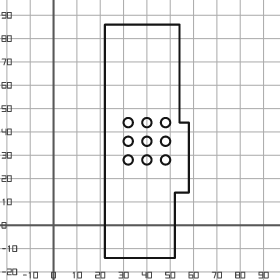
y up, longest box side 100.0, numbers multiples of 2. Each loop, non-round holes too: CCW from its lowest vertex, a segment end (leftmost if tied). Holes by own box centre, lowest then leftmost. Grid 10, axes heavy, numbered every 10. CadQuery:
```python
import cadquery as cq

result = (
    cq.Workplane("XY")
    .moveTo(22.0, -14.0)
    .lineTo(52.0, -14.0)
    .lineTo(52.0, 14.0)
    .lineTo(58.0, 14.0)
    .lineTo(58.0, 44.0)
    .lineTo(54.0, 44.0)
    .lineTo(54.0, 86.0)
    .lineTo(22.0, 86.0)
    .close()
    .moveTo(32.0, 28.0)
    .circle(2.0)
    .moveTo(40.0, 28.0)
    .circle(2.0)
    .moveTo(48.0, 28.0)
    .circle(2.0)
    .moveTo(32.0, 36.0)
    .circle(2.0)
    .moveTo(40.0, 36.0)
    .circle(2.0)
    .moveTo(48.0, 36.0)
    .circle(2.0)
    .moveTo(32.0, 44.0)
    .circle(2.0)
    .moveTo(40.0, 44.0)
    .circle(2.0)
    .moveTo(48.0, 44.0)
    .circle(2.0)
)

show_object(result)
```